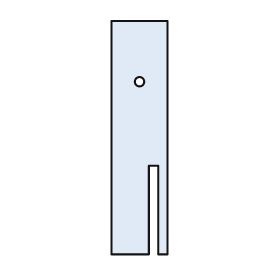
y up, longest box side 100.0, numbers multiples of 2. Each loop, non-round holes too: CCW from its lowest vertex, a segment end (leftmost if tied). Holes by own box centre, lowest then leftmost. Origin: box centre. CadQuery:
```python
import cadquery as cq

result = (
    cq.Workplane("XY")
    .moveTo(-12.0, -50.0)
    .lineTo(4.0, -50.0)
    .lineTo(4.0, -12.0)
    .lineTo(8.0, -12.0)
    .lineTo(8.0, -50.0)
    .lineTo(12.0, -50.0)
    .lineTo(12.0, 50.0)
    .lineTo(-12.0, 50.0)
    .close()
    .moveTo(0.0, 24.0)
    .circle(2.0)
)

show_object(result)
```